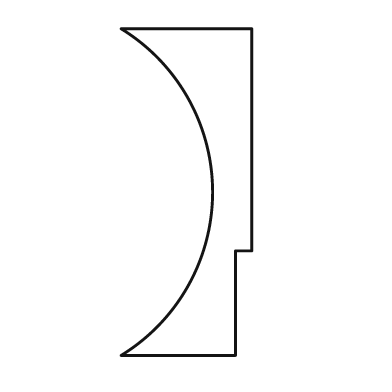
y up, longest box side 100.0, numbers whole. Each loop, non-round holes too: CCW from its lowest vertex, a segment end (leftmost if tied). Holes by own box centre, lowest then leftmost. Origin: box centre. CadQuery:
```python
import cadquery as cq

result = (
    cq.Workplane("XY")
    .moveTo(-20.0, -50.0)
    .lineTo(15.0, -50.0)
    .lineTo(15.0, -18.0)
    .lineTo(20.0, -18.0)
    .lineTo(20.0, 50.0)
    .lineTo(-20.0, 50.0)
    .threePointArc((8.0, 0.0), (-20.0, -50.0))
    .close()
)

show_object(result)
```